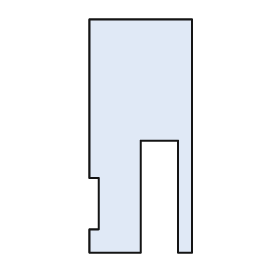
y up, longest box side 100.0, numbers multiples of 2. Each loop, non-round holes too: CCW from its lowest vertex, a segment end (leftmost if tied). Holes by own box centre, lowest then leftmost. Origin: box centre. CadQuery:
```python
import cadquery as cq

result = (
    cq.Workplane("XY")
    .moveTo(-22.0, -50.0)
    .lineTo(0.0, -50.0)
    .lineTo(0.0, -2.0)
    .lineTo(16.0, -2.0)
    .lineTo(16.0, -50.0)
    .lineTo(22.0, -50.0)
    .lineTo(22.0, 50.0)
    .lineTo(-22.0, 50.0)
    .lineTo(-22.0, -18.0)
    .lineTo(-18.0, -18.0)
    .lineTo(-18.0, -40.0)
    .lineTo(-22.0, -40.0)
    .close()
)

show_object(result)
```